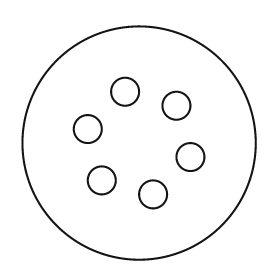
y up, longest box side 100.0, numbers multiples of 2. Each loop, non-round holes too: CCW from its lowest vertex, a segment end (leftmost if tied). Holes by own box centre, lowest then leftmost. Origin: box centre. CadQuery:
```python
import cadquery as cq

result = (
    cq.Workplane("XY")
    .moveTo(0.0, 0.0)
    .circle(50.0)
    .moveTo(6.0, -22.0)
    .circle(6.0)
    .moveTo(-16.0, -16.0)
    .circle(6.0)
    .moveTo(22.0, -6.0)
    .circle(6.0)
    .moveTo(-22.0, 6.0)
    .circle(6.0)
    .moveTo(16.0, 16.0)
    .circle(6.0)
    .moveTo(-6.0, 22.0)
    .circle(6.0)
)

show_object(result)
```